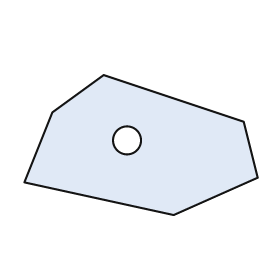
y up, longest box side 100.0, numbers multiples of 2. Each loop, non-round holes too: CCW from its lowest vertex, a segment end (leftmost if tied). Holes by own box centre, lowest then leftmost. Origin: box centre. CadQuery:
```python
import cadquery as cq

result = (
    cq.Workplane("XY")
    .moveTo(14.0, -30.0)
    .lineTo(50.0, -14.0)
    .lineTo(44.0, 10.0)
    .lineTo(-16.0, 30.0)
    .lineTo(-38.0, 14.0)
    .lineTo(-50.0, -16.0)
    .close()
    .moveTo(-6.0, 2.0)
    .circle(6.0)
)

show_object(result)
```